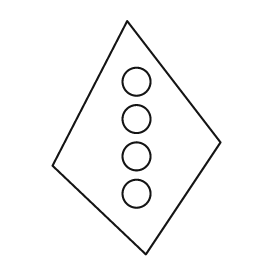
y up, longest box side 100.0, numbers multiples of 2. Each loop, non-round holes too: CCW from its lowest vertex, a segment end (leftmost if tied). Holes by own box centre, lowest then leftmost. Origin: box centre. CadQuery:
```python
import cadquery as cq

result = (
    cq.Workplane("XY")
    .moveTo(4.0, -50.0)
    .lineTo(36.0, -2.0)
    .lineTo(-4.0, 50.0)
    .lineTo(-36.0, -12.0)
    .close()
    .moveTo(0.0, -24.0)
    .circle(6.0)
    .moveTo(0.0, -8.0)
    .circle(6.0)
    .moveTo(0.0, 8.0)
    .circle(6.0)
    .moveTo(0.0, 24.0)
    .circle(6.0)
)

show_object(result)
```